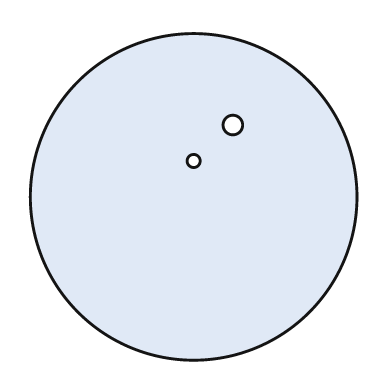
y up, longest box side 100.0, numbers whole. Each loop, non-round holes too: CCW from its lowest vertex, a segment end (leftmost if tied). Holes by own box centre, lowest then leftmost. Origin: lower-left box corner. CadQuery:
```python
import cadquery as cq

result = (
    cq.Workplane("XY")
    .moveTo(50.0, 50.0)
    .circle(50.0)
    .moveTo(50.0, 61.0)
    .circle(2.0)
    .moveTo(62.0, 72.0)
    .circle(3.0)
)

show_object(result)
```